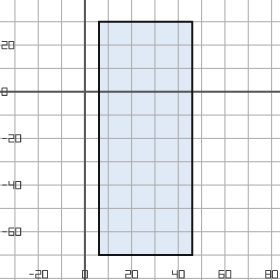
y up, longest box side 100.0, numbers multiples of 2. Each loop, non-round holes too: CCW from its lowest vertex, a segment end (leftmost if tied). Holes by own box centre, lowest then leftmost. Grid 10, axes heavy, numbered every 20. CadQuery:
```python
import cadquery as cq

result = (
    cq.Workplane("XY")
    .moveTo(6.0, -70.0)
    .lineTo(46.0, -70.0)
    .lineTo(46.0, 30.0)
    .lineTo(6.0, 30.0)
    .close()
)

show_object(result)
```